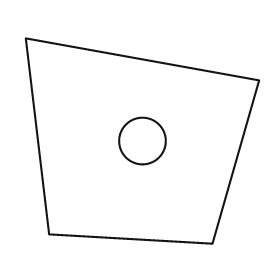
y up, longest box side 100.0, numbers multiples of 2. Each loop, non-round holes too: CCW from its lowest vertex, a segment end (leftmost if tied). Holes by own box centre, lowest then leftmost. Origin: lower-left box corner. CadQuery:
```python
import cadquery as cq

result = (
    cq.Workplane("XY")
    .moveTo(80.0, 0.0)
    .lineTo(100.0, 70.0)
    .lineTo(0.0, 88.0)
    .lineTo(10.0, 4.0)
    .close()
    .moveTo(50.0, 44.0)
    .circle(10.0)
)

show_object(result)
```